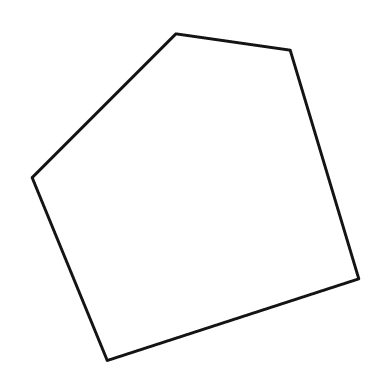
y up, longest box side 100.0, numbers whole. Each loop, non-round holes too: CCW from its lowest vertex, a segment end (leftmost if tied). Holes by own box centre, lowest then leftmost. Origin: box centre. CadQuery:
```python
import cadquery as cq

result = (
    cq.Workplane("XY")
    .moveTo(-27.0, -50.0)
    .lineTo(50.0, -25.0)
    .lineTo(29.0, 45.0)
    .lineTo(-6.0, 50.0)
    .lineTo(-50.0, 6.0)
    .close()
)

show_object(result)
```